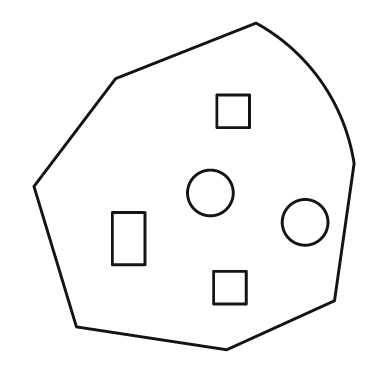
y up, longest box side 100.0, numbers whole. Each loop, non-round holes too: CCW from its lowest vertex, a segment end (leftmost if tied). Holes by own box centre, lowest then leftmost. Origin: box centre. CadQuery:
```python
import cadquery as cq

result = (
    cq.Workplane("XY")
    .moveTo(10.0, -50.0)
    .lineTo(43.0, -35.0)
    .lineTo(49.0, 7.0)
    .threePointArc((39.0, 32.0), (19.0, 50.0))
    .lineTo(-24.0, 33.0)
    .lineTo(-49.0, 0.0)
    .lineTo(-36.0, -43.0)
    .close()
    .moveTo(6.0, -36.0)
    .lineTo(16.0, -36.0)
    .lineTo(16.0, -26.0)
    .lineTo(6.0, -26.0)
    .close()
    .moveTo(-25.0, -24.0)
    .lineTo(-15.0, -24.0)
    .lineTo(-15.0, -8.0)
    .lineTo(-25.0, -8.0)
    .close()
    .moveTo(34.0, -11.0)
    .circle(7.0)
    .moveTo(5.0, -2.0)
    .circle(7.0)
    .moveTo(7.0, 18.0)
    .lineTo(17.0, 18.0)
    .lineTo(17.0, 28.0)
    .lineTo(7.0, 28.0)
    .close()
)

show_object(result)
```